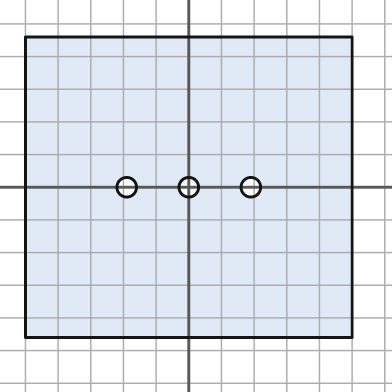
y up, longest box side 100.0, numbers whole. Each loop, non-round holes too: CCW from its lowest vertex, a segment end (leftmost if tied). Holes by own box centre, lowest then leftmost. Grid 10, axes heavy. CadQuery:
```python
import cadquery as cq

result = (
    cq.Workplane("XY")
    .moveTo(-50.0, -46.0)
    .lineTo(50.0, -46.0)
    .lineTo(50.0, 46.0)
    .lineTo(-50.0, 46.0)
    .close()
    .moveTo(-19.0, 0.0)
    .circle(3.0)
    .moveTo(0.0, 0.0)
    .circle(3.0)
    .moveTo(19.0, 0.0)
    .circle(3.0)
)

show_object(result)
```